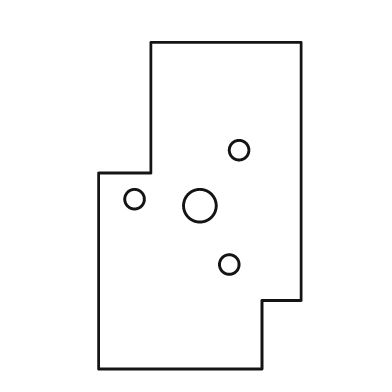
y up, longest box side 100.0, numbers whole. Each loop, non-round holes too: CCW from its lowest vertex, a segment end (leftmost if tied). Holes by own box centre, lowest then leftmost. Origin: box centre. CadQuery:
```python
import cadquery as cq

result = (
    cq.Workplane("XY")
    .moveTo(-31.0, -50.0)
    .lineTo(19.0, -50.0)
    .lineTo(19.0, -29.0)
    .lineTo(31.0, -29.0)
    .lineTo(31.0, 50.0)
    .lineTo(-15.0, 50.0)
    .lineTo(-15.0, 10.0)
    .lineTo(-31.0, 10.0)
    .close()
    .moveTo(9.0, -18.0)
    .circle(3.0)
    .moveTo(0.0, 0.0)
    .circle(5.0)
    .moveTo(-20.0, 2.0)
    .circle(3.0)
    .moveTo(12.0, 17.0)
    .circle(3.0)
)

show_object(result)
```